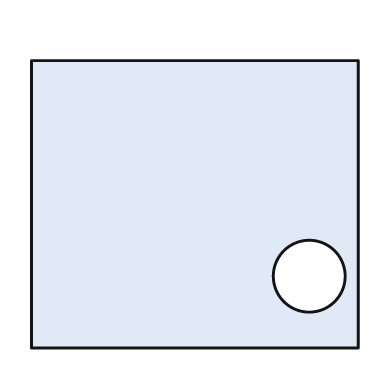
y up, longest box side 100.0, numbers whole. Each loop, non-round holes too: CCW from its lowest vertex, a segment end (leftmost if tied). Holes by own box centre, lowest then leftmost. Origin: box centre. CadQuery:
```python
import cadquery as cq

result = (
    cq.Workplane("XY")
    .moveTo(-50.0, -44.0)
    .lineTo(50.0, -44.0)
    .lineTo(50.0, 44.0)
    .lineTo(-50.0, 44.0)
    .close()
    .moveTo(35.0, -22.0)
    .circle(11.0)
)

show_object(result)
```